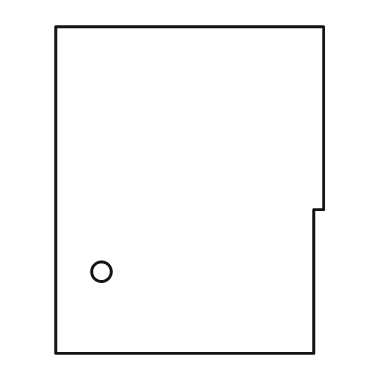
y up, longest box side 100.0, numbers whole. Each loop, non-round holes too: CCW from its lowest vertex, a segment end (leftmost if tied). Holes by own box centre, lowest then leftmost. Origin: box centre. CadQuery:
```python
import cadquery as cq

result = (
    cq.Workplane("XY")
    .moveTo(-41.0, -50.0)
    .lineTo(38.0, -50.0)
    .lineTo(38.0, -6.0)
    .lineTo(41.0, -6.0)
    .lineTo(41.0, 50.0)
    .lineTo(-41.0, 50.0)
    .close()
    .moveTo(-27.0, -25.0)
    .circle(3.0)
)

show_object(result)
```